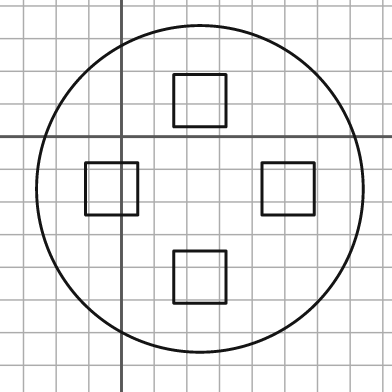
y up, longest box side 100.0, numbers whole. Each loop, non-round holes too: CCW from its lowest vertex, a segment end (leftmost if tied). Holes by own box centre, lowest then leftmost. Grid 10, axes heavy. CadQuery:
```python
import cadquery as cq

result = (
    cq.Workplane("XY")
    .moveTo(24.0, -16.0)
    .circle(50.0)
    .moveTo(16.0, -51.0)
    .lineTo(32.0, -51.0)
    .lineTo(32.0, -35.0)
    .lineTo(16.0, -35.0)
    .close()
    .moveTo(-11.0, -24.0)
    .lineTo(5.0, -24.0)
    .lineTo(5.0, -8.0)
    .lineTo(-11.0, -8.0)
    .close()
    .moveTo(43.0, -24.0)
    .lineTo(59.0, -24.0)
    .lineTo(59.0, -8.0)
    .lineTo(43.0, -8.0)
    .close()
    .moveTo(16.0, 3.0)
    .lineTo(32.0, 3.0)
    .lineTo(32.0, 19.0)
    .lineTo(16.0, 19.0)
    .close()
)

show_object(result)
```